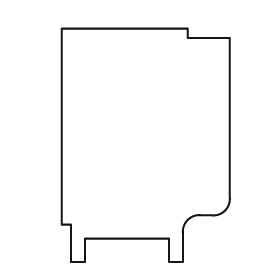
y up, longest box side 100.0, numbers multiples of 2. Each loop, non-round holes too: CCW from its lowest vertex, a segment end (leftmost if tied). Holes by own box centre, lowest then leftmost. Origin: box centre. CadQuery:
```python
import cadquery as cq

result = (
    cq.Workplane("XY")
    .moveTo(-32.0, -50.0)
    .lineTo(-26.0, -50.0)
    .lineTo(-26.0, -40.0)
    .lineTo(10.0, -40.0)
    .lineTo(10.0, -50.0)
    .lineTo(16.0, -50.0)
    .lineTo(16.0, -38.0)
    .threePointArc((18.0, -32.0), (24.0, -30.0))
    .lineTo(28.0, -30.0)
    .threePointArc((34.0, -28.0), (36.0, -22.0))
    .lineTo(36.0, 46.0)
    .lineTo(18.0, 46.0)
    .lineTo(18.0, 50.0)
    .lineTo(-36.0, 50.0)
    .lineTo(-36.0, -34.0)
    .lineTo(-32.0, -34.0)
    .close()
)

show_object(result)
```